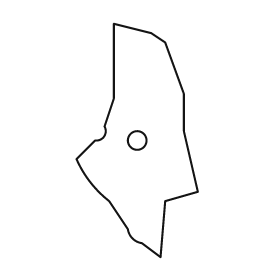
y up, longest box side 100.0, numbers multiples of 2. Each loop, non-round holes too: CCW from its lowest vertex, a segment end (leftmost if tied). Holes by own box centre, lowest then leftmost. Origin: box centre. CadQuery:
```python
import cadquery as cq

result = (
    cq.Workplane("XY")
    .moveTo(10.0, -50.0)
    .lineTo(12.0, -26.0)
    .lineTo(26.0, -22.0)
    .lineTo(20.0, 4.0)
    .lineTo(20.0, 20.0)
    .lineTo(12.0, 42.0)
    .lineTo(6.0, 46.0)
    .lineTo(-10.0, 50.0)
    .lineTo(-10.0, 18.0)
    .lineTo(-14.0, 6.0)
    .threePointArc((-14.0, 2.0), (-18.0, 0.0))
    .lineTo(-26.0, -8.0)
    .threePointArc((-20.0, -18.0), (-12.0, -26.0))
    .lineTo(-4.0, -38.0)
    .threePointArc((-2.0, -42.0), (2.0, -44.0))
    .close()
    .moveTo(0.0, 0.0)
    .circle(4.0)
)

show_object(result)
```